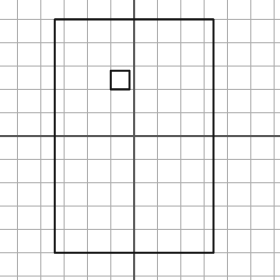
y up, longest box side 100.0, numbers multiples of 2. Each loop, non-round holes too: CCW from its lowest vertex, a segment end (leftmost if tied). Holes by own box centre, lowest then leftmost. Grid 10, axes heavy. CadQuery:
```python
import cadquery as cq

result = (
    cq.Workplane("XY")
    .moveTo(-34.0, -50.0)
    .lineTo(34.0, -50.0)
    .lineTo(34.0, 50.0)
    .lineTo(-34.0, 50.0)
    .close()
    .moveTo(-10.0, 20.0)
    .lineTo(-2.0, 20.0)
    .lineTo(-2.0, 28.0)
    .lineTo(-10.0, 28.0)
    .close()
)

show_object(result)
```